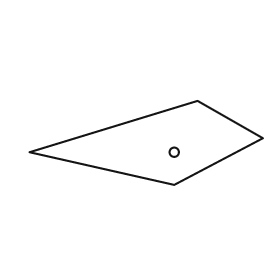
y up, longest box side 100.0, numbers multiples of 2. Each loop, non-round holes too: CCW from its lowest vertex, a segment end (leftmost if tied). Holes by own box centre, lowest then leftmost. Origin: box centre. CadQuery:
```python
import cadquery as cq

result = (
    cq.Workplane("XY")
    .moveTo(12.0, -18.0)
    .lineTo(50.0, 2.0)
    .lineTo(22.0, 18.0)
    .lineTo(-50.0, -4.0)
    .close()
    .moveTo(12.0, -4.0)
    .circle(2.0)
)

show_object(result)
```